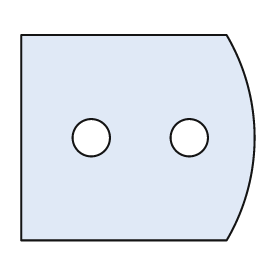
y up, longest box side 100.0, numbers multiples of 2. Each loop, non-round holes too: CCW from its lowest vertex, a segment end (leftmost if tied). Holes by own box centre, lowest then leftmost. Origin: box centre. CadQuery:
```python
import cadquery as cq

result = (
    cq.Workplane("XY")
    .moveTo(-50.0, -44.0)
    .lineTo(38.0, -44.0)
    .threePointArc((50.0, 0.0), (38.0, 44.0))
    .lineTo(-50.0, 44.0)
    .close()
    .moveTo(-20.0, 0.0)
    .circle(8.0)
    .moveTo(22.0, 0.0)
    .circle(8.0)
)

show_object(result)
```